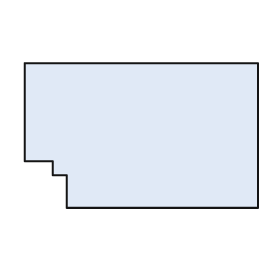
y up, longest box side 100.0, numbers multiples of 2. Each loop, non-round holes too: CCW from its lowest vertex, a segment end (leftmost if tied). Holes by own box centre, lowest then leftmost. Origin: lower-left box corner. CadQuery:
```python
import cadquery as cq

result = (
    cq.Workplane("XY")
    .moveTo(18.0, 0.0)
    .lineTo(100.0, 0.0)
    .lineTo(100.0, 62.0)
    .lineTo(0.0, 62.0)
    .lineTo(0.0, 20.0)
    .lineTo(12.0, 20.0)
    .lineTo(12.0, 14.0)
    .lineTo(18.0, 14.0)
    .close()
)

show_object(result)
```